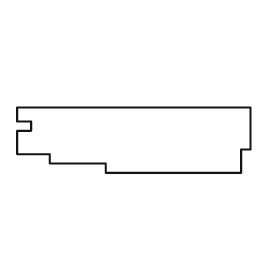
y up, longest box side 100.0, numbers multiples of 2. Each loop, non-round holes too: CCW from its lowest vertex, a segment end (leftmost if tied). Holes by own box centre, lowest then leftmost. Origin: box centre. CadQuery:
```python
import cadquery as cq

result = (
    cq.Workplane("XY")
    .moveTo(-12.0, -14.0)
    .lineTo(46.0, -14.0)
    .lineTo(46.0, -4.0)
    .lineTo(50.0, -4.0)
    .lineTo(50.0, 14.0)
    .lineTo(-50.0, 14.0)
    .lineTo(-50.0, 8.0)
    .lineTo(-44.0, 8.0)
    .lineTo(-44.0, 4.0)
    .lineTo(-50.0, 4.0)
    .lineTo(-50.0, -6.0)
    .lineTo(-36.0, -6.0)
    .lineTo(-36.0, -10.0)
    .lineTo(-12.0, -10.0)
    .close()
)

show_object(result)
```